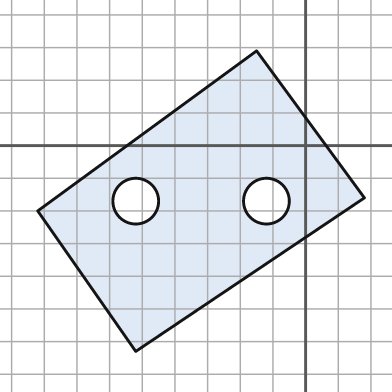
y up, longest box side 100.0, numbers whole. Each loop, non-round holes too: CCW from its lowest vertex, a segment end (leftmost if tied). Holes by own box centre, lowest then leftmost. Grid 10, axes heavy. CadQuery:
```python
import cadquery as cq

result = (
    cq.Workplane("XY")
    .moveTo(-52.0, -63.0)
    .lineTo(18.0, -16.0)
    .lineTo(-15.0, 29.0)
    .lineTo(-82.0, -20.0)
    .close()
    .moveTo(-52.0, -17.0)
    .circle(7.0)
    .moveTo(-12.0, -17.0)
    .circle(7.0)
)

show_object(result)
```